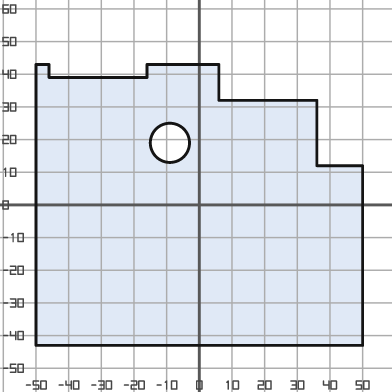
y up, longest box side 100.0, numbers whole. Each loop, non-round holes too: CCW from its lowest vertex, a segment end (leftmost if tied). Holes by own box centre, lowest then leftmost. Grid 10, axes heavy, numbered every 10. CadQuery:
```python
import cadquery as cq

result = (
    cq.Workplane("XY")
    .moveTo(-50.0, -43.0)
    .lineTo(50.0, -43.0)
    .lineTo(50.0, 12.0)
    .lineTo(36.0, 12.0)
    .lineTo(36.0, 32.0)
    .lineTo(6.0, 32.0)
    .lineTo(6.0, 43.0)
    .lineTo(-16.0, 43.0)
    .lineTo(-16.0, 39.0)
    .lineTo(-46.0, 39.0)
    .lineTo(-46.0, 43.0)
    .lineTo(-50.0, 43.0)
    .close()
    .moveTo(-9.0, 19.0)
    .circle(6.0)
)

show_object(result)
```